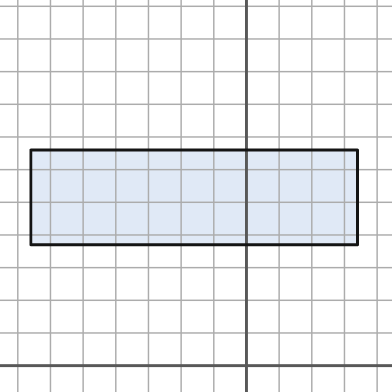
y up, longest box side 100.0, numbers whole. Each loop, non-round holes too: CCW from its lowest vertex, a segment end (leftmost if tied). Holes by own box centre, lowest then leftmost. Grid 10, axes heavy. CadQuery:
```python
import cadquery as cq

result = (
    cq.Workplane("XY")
    .moveTo(-66.0, 37.0)
    .lineTo(34.0, 37.0)
    .lineTo(34.0, 66.0)
    .lineTo(-66.0, 66.0)
    .close()
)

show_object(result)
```